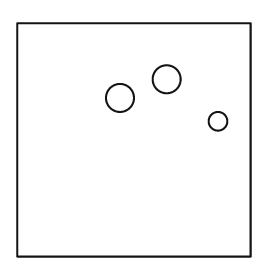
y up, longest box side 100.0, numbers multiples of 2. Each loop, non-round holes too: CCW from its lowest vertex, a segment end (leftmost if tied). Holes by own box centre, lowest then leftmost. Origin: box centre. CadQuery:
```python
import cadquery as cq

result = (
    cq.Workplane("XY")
    .moveTo(-50.0, -50.0)
    .lineTo(50.0, -50.0)
    .lineTo(50.0, 50.0)
    .lineTo(-50.0, 50.0)
    .close()
    .moveTo(36.0, 8.0)
    .circle(4.0)
    .moveTo(-6.0, 18.0)
    .circle(6.0)
    .moveTo(14.0, 26.0)
    .circle(6.0)
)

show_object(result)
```